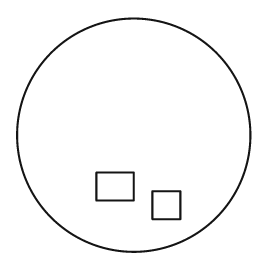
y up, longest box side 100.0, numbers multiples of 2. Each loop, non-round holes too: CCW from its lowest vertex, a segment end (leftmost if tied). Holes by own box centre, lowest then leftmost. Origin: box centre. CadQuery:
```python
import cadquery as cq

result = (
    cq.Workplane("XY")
    .moveTo(0.0, 0.0)
    .circle(50.0)
    .moveTo(8.0, -36.0)
    .lineTo(20.0, -36.0)
    .lineTo(20.0, -24.0)
    .lineTo(8.0, -24.0)
    .close()
    .moveTo(-16.0, -28.0)
    .lineTo(0.0, -28.0)
    .lineTo(0.0, -16.0)
    .lineTo(-16.0, -16.0)
    .close()
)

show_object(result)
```